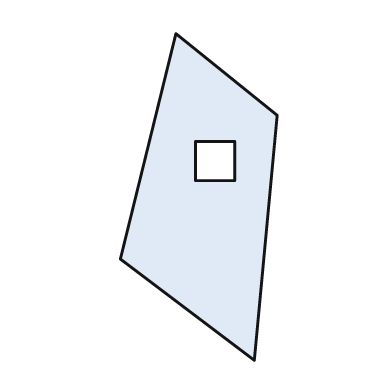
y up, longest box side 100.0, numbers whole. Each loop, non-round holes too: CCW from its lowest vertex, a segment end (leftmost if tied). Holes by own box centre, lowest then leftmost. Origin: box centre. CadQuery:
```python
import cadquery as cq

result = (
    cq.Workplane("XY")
    .moveTo(17.0, -50.0)
    .lineTo(24.0, 25.0)
    .lineTo(-7.0, 50.0)
    .lineTo(-24.0, -19.0)
    .close()
    .moveTo(-1.0, 5.0)
    .lineTo(11.0, 5.0)
    .lineTo(11.0, 17.0)
    .lineTo(-1.0, 17.0)
    .close()
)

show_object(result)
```